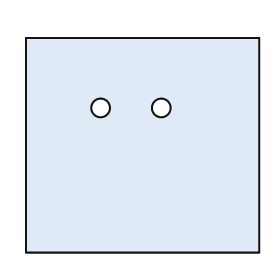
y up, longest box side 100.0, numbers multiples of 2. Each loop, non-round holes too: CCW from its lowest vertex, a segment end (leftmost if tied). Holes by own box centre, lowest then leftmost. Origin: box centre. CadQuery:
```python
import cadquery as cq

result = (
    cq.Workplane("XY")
    .moveTo(-50.0, -46.0)
    .lineTo(50.0, -46.0)
    .lineTo(50.0, 46.0)
    .lineTo(-50.0, 46.0)
    .close()
    .moveTo(-18.0, 16.0)
    .circle(4.0)
    .moveTo(8.0, 16.0)
    .circle(4.0)
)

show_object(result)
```